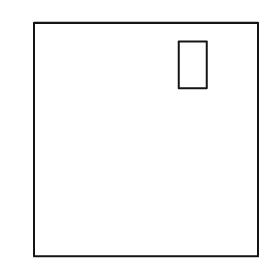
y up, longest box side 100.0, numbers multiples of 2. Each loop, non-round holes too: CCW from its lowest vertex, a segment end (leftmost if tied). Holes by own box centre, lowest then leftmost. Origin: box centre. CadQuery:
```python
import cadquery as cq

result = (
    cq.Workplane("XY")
    .moveTo(-48.0, -50.0)
    .lineTo(48.0, -50.0)
    .lineTo(48.0, 50.0)
    .lineTo(-48.0, 50.0)
    .close()
    .moveTo(14.0, 22.0)
    .lineTo(26.0, 22.0)
    .lineTo(26.0, 42.0)
    .lineTo(14.0, 42.0)
    .close()
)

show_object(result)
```